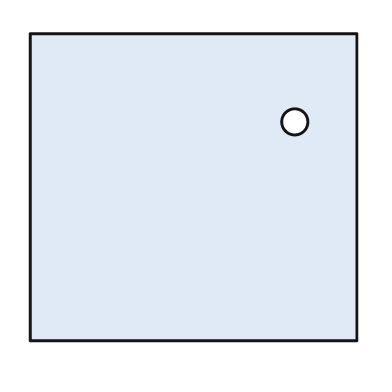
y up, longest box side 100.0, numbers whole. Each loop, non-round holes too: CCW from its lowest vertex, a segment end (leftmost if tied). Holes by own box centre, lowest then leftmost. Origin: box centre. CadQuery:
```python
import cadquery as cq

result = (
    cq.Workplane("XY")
    .moveTo(-50.0, -47.0)
    .lineTo(50.0, -47.0)
    .lineTo(50.0, 47.0)
    .lineTo(-50.0, 47.0)
    .close()
    .moveTo(31.0, 20.0)
    .circle(4.0)
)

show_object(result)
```